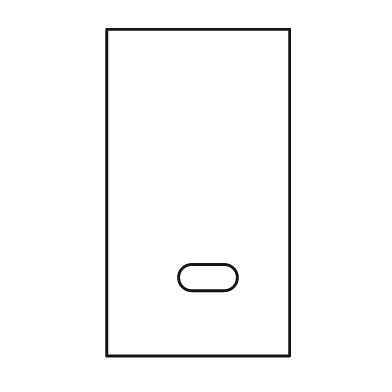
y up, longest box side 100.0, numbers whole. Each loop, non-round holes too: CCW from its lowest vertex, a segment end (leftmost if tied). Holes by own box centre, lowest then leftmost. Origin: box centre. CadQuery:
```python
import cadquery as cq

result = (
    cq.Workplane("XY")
    .moveTo(-28.0, -50.0)
    .lineTo(28.0, -50.0)
    .lineTo(28.0, 50.0)
    .lineTo(-28.0, 50.0)
    .close()
    .moveTo(-2.0, -30.0)
    .lineTo(8.0, -30.0)
    .threePointArc((12.0, -26.0), (8.0, -22.0))
    .lineTo(-2.0, -22.0)
    .threePointArc((-6.0, -26.0), (-2.0, -30.0))
    .close()
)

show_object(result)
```